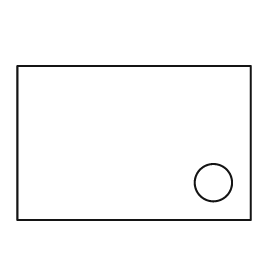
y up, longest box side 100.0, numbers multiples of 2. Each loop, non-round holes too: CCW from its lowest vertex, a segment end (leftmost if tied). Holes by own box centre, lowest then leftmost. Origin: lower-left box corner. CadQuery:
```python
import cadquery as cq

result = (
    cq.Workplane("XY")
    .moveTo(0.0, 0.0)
    .lineTo(100.0, 0.0)
    .lineTo(100.0, 66.0)
    .lineTo(0.0, 66.0)
    .close()
    .moveTo(84.0, 16.0)
    .circle(8.0)
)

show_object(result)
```